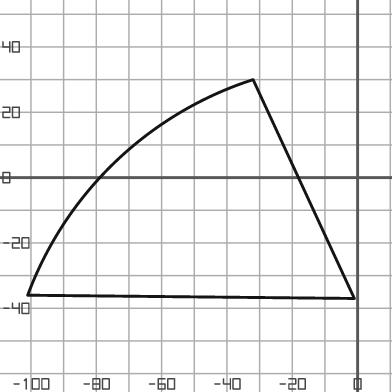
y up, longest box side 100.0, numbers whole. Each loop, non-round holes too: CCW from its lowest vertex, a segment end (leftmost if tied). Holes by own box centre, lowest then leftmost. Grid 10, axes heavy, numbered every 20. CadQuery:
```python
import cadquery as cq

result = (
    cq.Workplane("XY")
    .moveTo(-1.0, -37.0)
    .lineTo(-32.0, 30.0)
    .threePointArc((-74.0, 5.0), (-101.0, -36.0))
    .close()
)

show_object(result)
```